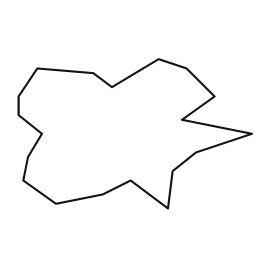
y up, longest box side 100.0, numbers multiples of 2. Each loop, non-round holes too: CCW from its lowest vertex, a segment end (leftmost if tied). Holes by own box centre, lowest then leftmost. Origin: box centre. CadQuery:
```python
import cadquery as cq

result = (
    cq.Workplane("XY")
    .moveTo(14.0, -32.0)
    .lineTo(16.0, -16.0)
    .lineTo(26.0, -8.0)
    .lineTo(50.0, 0.0)
    .lineTo(20.0, 6.0)
    .lineTo(34.0, 16.0)
    .lineTo(22.0, 28.0)
    .lineTo(10.0, 32.0)
    .lineTo(-10.0, 20.0)
    .lineTo(-18.0, 26.0)
    .lineTo(-42.0, 28.0)
    .lineTo(-50.0, 16.0)
    .lineTo(-50.0, 8.0)
    .lineTo(-40.0, 0.0)
    .lineTo(-46.0, -10.0)
    .lineTo(-48.0, -20.0)
    .lineTo(-34.0, -30.0)
    .lineTo(-14.0, -26.0)
    .lineTo(-2.0, -20.0)
    .close()
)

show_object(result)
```